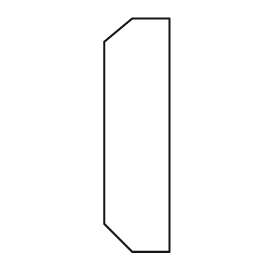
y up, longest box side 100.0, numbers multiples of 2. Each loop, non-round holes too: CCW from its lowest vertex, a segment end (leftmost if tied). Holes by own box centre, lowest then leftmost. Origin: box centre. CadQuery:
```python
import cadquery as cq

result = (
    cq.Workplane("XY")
    .moveTo(-2.0, -50.0)
    .lineTo(14.0, -50.0)
    .lineTo(14.0, 50.0)
    .lineTo(-2.0, 50.0)
    .lineTo(-14.0, 40.0)
    .lineTo(-14.0, -38.0)
    .close()
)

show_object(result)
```